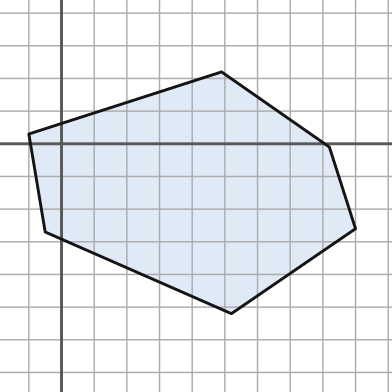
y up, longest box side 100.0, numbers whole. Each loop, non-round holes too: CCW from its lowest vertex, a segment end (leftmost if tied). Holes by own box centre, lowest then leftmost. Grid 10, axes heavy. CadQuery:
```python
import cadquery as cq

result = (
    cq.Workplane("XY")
    .moveTo(52.0, -52.0)
    .lineTo(90.0, -26.0)
    .lineTo(82.0, -1.0)
    .lineTo(49.0, 22.0)
    .lineTo(-10.0, 3.0)
    .lineTo(-5.0, -27.0)
    .close()
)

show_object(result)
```